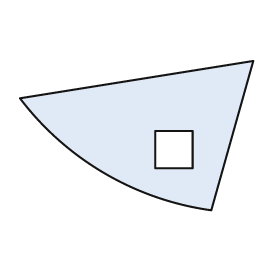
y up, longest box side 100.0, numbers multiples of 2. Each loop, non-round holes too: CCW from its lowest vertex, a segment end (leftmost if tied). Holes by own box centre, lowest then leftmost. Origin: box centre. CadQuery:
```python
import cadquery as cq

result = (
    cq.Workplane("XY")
    .moveTo(32.0, -32.0)
    .lineTo(50.0, 32.0)
    .lineTo(-50.0, 16.0)
    .threePointArc((-14.0, -16.0), (32.0, -32.0))
    .close()
    .moveTo(8.0, -14.0)
    .lineTo(24.0, -14.0)
    .lineTo(24.0, 2.0)
    .lineTo(8.0, 2.0)
    .close()
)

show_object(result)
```